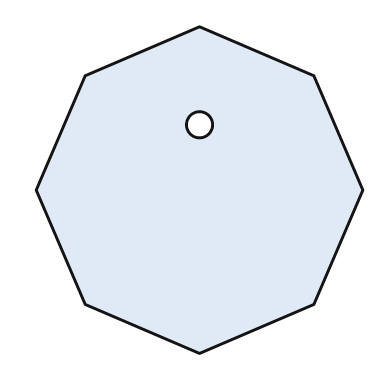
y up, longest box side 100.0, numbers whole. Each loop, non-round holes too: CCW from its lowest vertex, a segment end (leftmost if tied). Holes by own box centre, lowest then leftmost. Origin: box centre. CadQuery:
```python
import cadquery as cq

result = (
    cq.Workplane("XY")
    .moveTo(0.0, -50.0)
    .lineTo(35.0, -35.0)
    .lineTo(50.0, 0.0)
    .lineTo(35.0, 35.0)
    .lineTo(0.0, 50.0)
    .lineTo(-35.0, 35.0)
    .lineTo(-50.0, 0.0)
    .lineTo(-35.0, -35.0)
    .close()
    .moveTo(0.0, 20.0)
    .circle(4.0)
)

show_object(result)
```